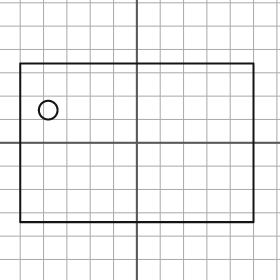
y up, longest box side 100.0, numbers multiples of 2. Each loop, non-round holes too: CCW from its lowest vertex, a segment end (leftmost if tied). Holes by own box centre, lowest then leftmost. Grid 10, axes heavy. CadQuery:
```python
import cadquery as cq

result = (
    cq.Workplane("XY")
    .moveTo(-50.0, -34.0)
    .lineTo(50.0, -34.0)
    .lineTo(50.0, 34.0)
    .lineTo(-50.0, 34.0)
    .close()
    .moveTo(-38.0, 14.0)
    .circle(4.0)
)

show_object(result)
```